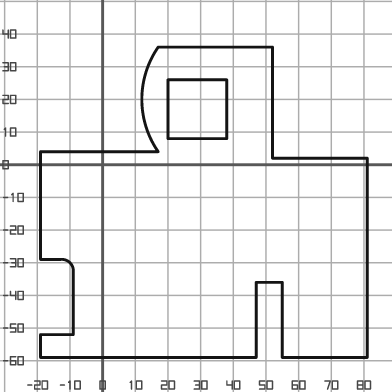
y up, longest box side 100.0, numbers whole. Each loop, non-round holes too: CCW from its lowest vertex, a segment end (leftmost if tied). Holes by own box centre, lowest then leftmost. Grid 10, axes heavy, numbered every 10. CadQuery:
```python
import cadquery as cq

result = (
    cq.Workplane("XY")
    .moveTo(-19.0, -59.0)
    .lineTo(47.0, -59.0)
    .lineTo(47.0, -36.0)
    .lineTo(55.0, -36.0)
    .lineTo(55.0, -59.0)
    .lineTo(81.0, -59.0)
    .lineTo(81.0, 2.0)
    .lineTo(52.0, 2.0)
    .lineTo(52.0, 36.0)
    .lineTo(17.0, 36.0)
    .threePointArc((12.0, 20.0), (17.0, 4.0))
    .lineTo(-19.0, 4.0)
    .lineTo(-19.0, -29.0)
    .lineTo(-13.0, -29.0)
    .threePointArc((-10.0, -30.0), (-9.0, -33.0))
    .lineTo(-9.0, -52.0)
    .lineTo(-19.0, -52.0)
    .close()
    .moveTo(20.0, 8.0)
    .lineTo(38.0, 8.0)
    .lineTo(38.0, 26.0)
    .lineTo(20.0, 26.0)
    .close()
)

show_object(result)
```